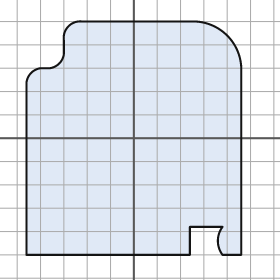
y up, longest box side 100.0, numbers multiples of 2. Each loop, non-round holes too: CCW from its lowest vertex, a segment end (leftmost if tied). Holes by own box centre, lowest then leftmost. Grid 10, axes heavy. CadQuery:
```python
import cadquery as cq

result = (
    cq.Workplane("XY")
    .moveTo(-46.0, -50.0)
    .lineTo(24.0, -50.0)
    .lineTo(24.0, -38.0)
    .lineTo(38.0, -38.0)
    .threePointArc((36.0, -44.0), (38.0, -50.0))
    .lineTo(46.0, -50.0)
    .lineTo(46.0, 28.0)
    .threePointArc((40.0, 44.0), (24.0, 50.0))
    .lineTo(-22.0, 50.0)
    .threePointArc((-28.0, 48.0), (-30.0, 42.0))
    .lineTo(-30.0, 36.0)
    .threePointArc((-32.0, 32.0), (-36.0, 30.0))
    .lineTo(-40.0, 30.0)
    .threePointArc((-44.0, 28.0), (-46.0, 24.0))
    .close()
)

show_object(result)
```